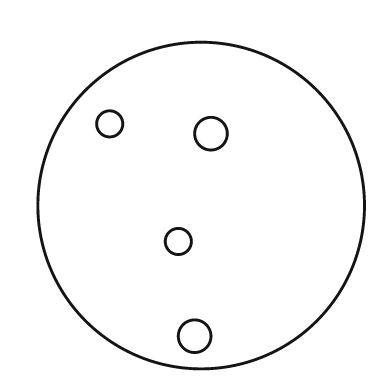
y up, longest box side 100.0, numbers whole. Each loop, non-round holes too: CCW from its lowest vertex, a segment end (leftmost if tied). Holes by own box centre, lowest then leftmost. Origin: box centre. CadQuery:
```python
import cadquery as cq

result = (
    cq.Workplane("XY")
    .moveTo(0.0, 0.0)
    .circle(50.0)
    .moveTo(-2.0, -40.0)
    .circle(5.0)
    .moveTo(-7.0, -11.0)
    .circle(4.0)
    .moveTo(3.0, 22.0)
    .circle(5.0)
    .moveTo(-28.0, 25.0)
    .circle(4.0)
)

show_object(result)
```